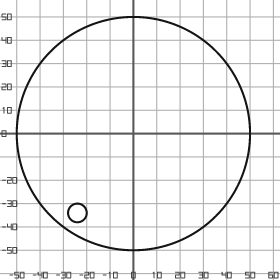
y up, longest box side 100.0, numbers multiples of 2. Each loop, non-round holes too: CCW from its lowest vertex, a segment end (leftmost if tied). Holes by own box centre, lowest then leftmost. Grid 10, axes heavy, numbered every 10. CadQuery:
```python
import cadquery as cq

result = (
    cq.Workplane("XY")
    .moveTo(0.0, 0.0)
    .circle(50.0)
    .moveTo(-24.0, -34.0)
    .circle(4.0)
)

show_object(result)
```